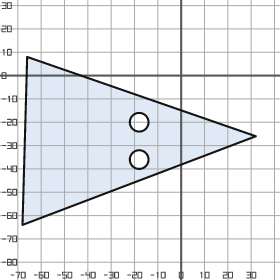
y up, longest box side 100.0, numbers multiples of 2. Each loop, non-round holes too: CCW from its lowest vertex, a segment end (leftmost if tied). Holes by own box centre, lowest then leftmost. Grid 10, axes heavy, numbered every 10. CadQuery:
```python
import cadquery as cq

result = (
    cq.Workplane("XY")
    .moveTo(-68.0, -64.0)
    .lineTo(32.0, -26.0)
    .lineTo(-66.0, 8.0)
    .close()
    .moveTo(-18.0, -36.0)
    .circle(4.0)
    .moveTo(-18.0, -20.0)
    .circle(4.0)
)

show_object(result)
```